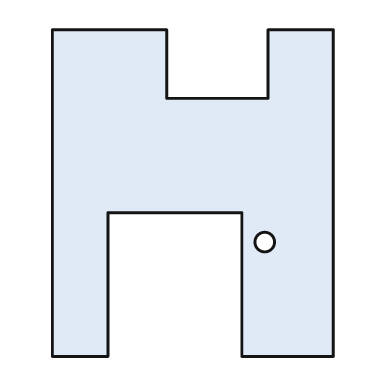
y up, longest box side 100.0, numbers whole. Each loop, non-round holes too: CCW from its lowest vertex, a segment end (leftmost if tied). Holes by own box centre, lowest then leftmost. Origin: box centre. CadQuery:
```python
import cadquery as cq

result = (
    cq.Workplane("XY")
    .moveTo(-43.0, -50.0)
    .lineTo(-26.0, -50.0)
    .lineTo(-26.0, -6.0)
    .lineTo(15.0, -6.0)
    .lineTo(15.0, -50.0)
    .lineTo(43.0, -50.0)
    .lineTo(43.0, 50.0)
    .lineTo(23.0, 50.0)
    .lineTo(23.0, 29.0)
    .lineTo(-8.0, 29.0)
    .lineTo(-8.0, 50.0)
    .lineTo(-43.0, 50.0)
    .close()
    .moveTo(22.0, -15.0)
    .circle(3.0)
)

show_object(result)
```